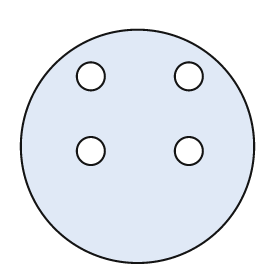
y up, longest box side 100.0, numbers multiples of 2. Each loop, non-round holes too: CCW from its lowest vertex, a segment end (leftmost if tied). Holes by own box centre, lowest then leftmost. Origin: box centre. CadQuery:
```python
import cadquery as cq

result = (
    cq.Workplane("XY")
    .moveTo(0.0, 0.0)
    .circle(50.0)
    .moveTo(-20.0, -2.0)
    .circle(6.0)
    .moveTo(22.0, -2.0)
    .circle(6.0)
    .moveTo(-20.0, 30.0)
    .circle(6.0)
    .moveTo(22.0, 30.0)
    .circle(6.0)
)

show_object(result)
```